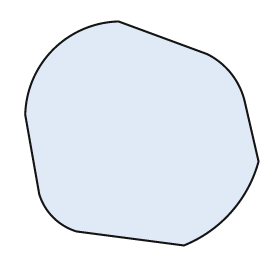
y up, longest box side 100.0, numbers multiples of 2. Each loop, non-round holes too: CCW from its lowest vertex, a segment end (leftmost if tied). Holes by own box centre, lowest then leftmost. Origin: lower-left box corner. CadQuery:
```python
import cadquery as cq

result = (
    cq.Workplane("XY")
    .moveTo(68.0, 0.0)
    .threePointArc((88.0, 14.0), (100.0, 36.0))
    .lineTo(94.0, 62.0)
    .threePointArc((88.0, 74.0), (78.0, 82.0))
    .lineTo(40.0, 96.0)
    .threePointArc((12.0, 84.0), (0.0, 56.0))
    .lineTo(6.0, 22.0)
    .threePointArc((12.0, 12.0), (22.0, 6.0))
    .close()
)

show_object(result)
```